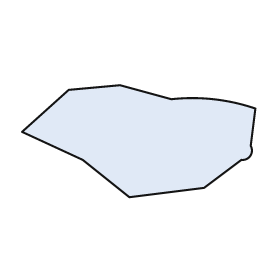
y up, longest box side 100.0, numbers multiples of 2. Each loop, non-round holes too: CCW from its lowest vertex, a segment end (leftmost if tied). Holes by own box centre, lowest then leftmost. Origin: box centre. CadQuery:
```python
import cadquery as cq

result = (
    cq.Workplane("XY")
    .moveTo(-4.0, -24.0)
    .lineTo(28.0, -20.0)
    .lineTo(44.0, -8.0)
    .threePointArc((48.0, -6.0), (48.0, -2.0))
    .lineTo(50.0, 14.0)
    .threePointArc((32.0, 18.0), (14.0, 18.0))
    .lineTo(-8.0, 24.0)
    .lineTo(-30.0, 22.0)
    .lineTo(-50.0, 4.0)
    .lineTo(-24.0, -8.0)
    .close()
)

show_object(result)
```